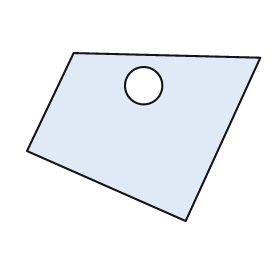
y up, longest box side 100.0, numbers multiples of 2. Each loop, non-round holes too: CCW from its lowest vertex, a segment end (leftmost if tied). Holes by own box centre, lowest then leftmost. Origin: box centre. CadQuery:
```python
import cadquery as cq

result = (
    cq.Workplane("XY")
    .moveTo(18.0, -36.0)
    .lineTo(50.0, 34.0)
    .lineTo(-30.0, 36.0)
    .lineTo(-50.0, -6.0)
    .close()
    .moveTo(0.0, 22.0)
    .circle(8.0)
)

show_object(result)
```